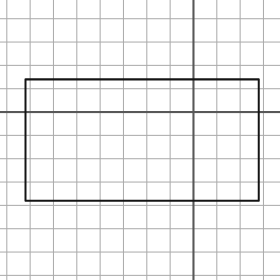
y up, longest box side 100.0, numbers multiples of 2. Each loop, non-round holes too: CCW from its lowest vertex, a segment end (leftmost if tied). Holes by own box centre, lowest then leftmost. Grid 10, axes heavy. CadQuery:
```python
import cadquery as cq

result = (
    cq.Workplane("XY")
    .moveTo(-72.0, -38.0)
    .lineTo(28.0, -38.0)
    .lineTo(28.0, 14.0)
    .lineTo(-72.0, 14.0)
    .close()
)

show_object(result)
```